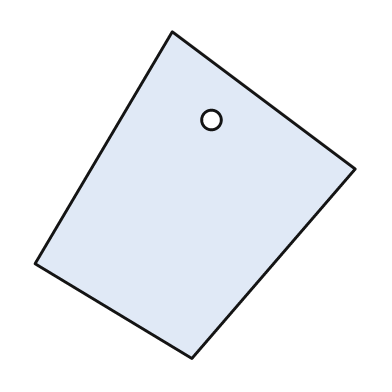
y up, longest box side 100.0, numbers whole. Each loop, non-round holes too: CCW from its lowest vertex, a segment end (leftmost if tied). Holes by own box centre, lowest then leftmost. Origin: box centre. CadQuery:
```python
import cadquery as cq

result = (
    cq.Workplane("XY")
    .moveTo(-1.0, -50.0)
    .lineTo(49.0, 8.0)
    .lineTo(-7.0, 50.0)
    .lineTo(-49.0, -21.0)
    .close()
    .moveTo(5.0, 23.0)
    .circle(3.0)
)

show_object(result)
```